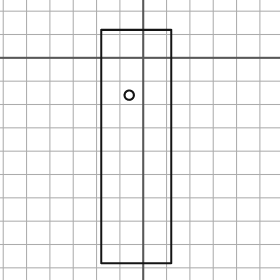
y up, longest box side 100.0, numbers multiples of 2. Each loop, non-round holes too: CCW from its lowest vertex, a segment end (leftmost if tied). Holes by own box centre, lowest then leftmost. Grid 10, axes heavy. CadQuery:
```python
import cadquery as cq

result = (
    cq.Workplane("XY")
    .moveTo(-18.0, -88.0)
    .lineTo(12.0, -88.0)
    .lineTo(12.0, 12.0)
    .lineTo(-18.0, 12.0)
    .close()
    .moveTo(-6.0, -16.0)
    .circle(2.0)
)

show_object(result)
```